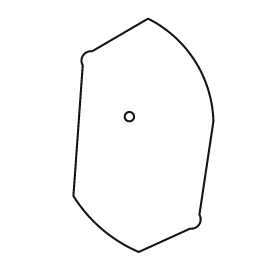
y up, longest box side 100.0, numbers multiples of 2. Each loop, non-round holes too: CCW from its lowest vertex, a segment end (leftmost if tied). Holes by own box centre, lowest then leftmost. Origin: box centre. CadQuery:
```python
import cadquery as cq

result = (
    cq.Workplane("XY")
    .moveTo(-2.0, -50.0)
    .lineTo(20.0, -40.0)
    .threePointArc((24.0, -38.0), (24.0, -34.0))
    .lineTo(30.0, 6.0)
    .threePointArc((22.0, 32.0), (2.0, 50.0))
    .lineTo(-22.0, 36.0)
    .threePointArc((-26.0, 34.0), (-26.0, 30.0))
    .lineTo(-30.0, -26.0)
    .threePointArc((-18.0, -40.0), (-2.0, -50.0))
    .close()
    .moveTo(-6.0, 8.0)
    .circle(2.0)
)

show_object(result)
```